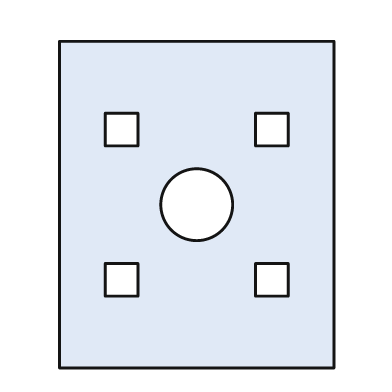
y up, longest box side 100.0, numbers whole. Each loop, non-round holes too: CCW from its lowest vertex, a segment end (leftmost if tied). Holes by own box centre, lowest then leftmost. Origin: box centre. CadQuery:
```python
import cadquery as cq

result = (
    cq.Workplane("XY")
    .moveTo(-42.0, -50.0)
    .lineTo(42.0, -50.0)
    .lineTo(42.0, 50.0)
    .lineTo(-42.0, 50.0)
    .close()
    .moveTo(-28.0, -28.0)
    .lineTo(-18.0, -28.0)
    .lineTo(-18.0, -18.0)
    .lineTo(-28.0, -18.0)
    .close()
    .moveTo(18.0, -28.0)
    .lineTo(28.0, -28.0)
    .lineTo(28.0, -18.0)
    .lineTo(18.0, -18.0)
    .close()
    .moveTo(0.0, 0.0)
    .circle(11.0)
    .moveTo(-28.0, 18.0)
    .lineTo(-18.0, 18.0)
    .lineTo(-18.0, 28.0)
    .lineTo(-28.0, 28.0)
    .close()
    .moveTo(18.0, 18.0)
    .lineTo(28.0, 18.0)
    .lineTo(28.0, 28.0)
    .lineTo(18.0, 28.0)
    .close()
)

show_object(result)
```